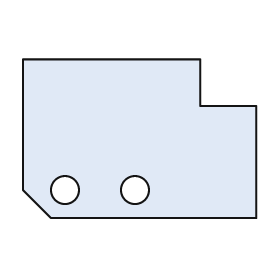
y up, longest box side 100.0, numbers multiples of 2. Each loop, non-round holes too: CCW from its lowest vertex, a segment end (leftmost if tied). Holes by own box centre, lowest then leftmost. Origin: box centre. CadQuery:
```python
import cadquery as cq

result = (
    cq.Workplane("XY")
    .moveTo(-38.0, -34.0)
    .lineTo(50.0, -34.0)
    .lineTo(50.0, 14.0)
    .lineTo(26.0, 14.0)
    .lineTo(26.0, 34.0)
    .lineTo(-50.0, 34.0)
    .lineTo(-50.0, -22.0)
    .close()
    .moveTo(-32.0, -22.0)
    .circle(6.0)
    .moveTo(-2.0, -22.0)
    .circle(6.0)
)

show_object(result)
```